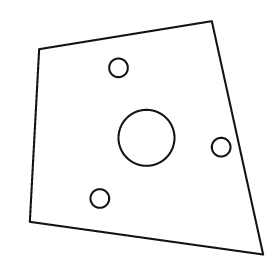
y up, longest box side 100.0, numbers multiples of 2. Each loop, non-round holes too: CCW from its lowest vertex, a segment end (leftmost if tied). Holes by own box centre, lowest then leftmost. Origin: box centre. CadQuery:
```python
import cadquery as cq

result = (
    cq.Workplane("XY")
    .moveTo(50.0, -50.0)
    .lineTo(28.0, 50.0)
    .lineTo(-46.0, 38.0)
    .lineTo(-50.0, -36.0)
    .close()
    .moveTo(-20.0, -26.0)
    .circle(4.0)
    .moveTo(32.0, -4.0)
    .circle(4.0)
    .moveTo(0.0, 0.0)
    .circle(12.0)
    .moveTo(-12.0, 30.0)
    .circle(4.0)
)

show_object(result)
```